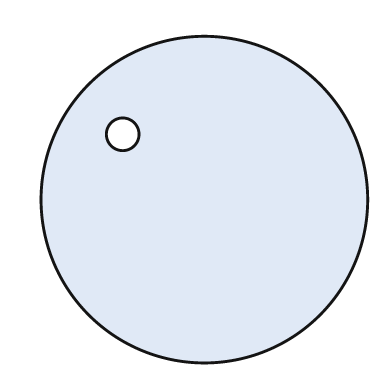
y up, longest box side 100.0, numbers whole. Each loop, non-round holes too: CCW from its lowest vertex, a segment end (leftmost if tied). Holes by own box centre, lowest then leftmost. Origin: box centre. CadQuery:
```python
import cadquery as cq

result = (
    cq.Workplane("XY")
    .moveTo(0.0, 0.0)
    .circle(50.0)
    .moveTo(-25.0, 20.0)
    .circle(5.0)
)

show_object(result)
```